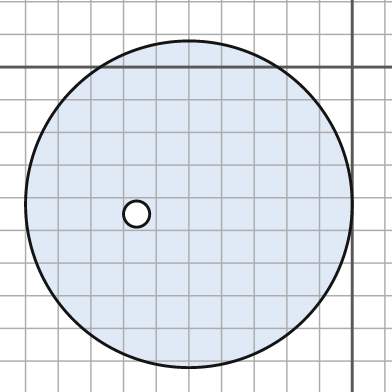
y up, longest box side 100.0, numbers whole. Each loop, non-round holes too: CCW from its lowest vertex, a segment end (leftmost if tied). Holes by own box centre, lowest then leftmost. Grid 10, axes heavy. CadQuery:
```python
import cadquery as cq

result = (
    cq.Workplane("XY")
    .moveTo(-50.0, -42.0)
    .circle(50.0)
    .moveTo(-66.0, -45.0)
    .circle(4.0)
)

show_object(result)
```